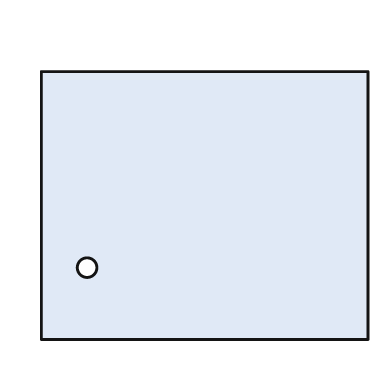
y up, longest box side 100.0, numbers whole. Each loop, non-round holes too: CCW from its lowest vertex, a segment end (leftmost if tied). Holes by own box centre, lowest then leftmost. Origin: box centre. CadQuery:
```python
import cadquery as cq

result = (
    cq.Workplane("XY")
    .moveTo(-50.0, -41.0)
    .lineTo(50.0, -41.0)
    .lineTo(50.0, 41.0)
    .lineTo(-50.0, 41.0)
    .close()
    .moveTo(-36.0, -19.0)
    .circle(3.0)
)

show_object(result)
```